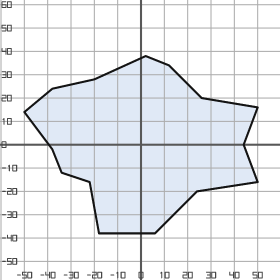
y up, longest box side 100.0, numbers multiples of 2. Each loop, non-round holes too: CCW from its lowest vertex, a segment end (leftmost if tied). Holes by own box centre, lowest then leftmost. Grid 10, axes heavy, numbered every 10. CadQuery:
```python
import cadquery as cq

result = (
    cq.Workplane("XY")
    .moveTo(-18.0, -38.0)
    .lineTo(6.0, -38.0)
    .lineTo(24.0, -20.0)
    .lineTo(50.0, -16.0)
    .lineTo(44.0, 0.0)
    .lineTo(50.0, 16.0)
    .lineTo(26.0, 20.0)
    .lineTo(12.0, 34.0)
    .lineTo(2.0, 38.0)
    .lineTo(-20.0, 28.0)
    .lineTo(-38.0, 24.0)
    .lineTo(-50.0, 14.0)
    .lineTo(-38.0, -2.0)
    .lineTo(-34.0, -12.0)
    .lineTo(-22.0, -16.0)
    .close()
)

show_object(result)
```